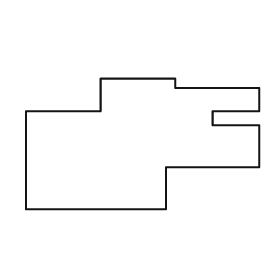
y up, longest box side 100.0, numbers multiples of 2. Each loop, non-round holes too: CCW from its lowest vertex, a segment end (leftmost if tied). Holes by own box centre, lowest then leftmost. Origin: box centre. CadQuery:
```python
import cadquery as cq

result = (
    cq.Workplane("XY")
    .moveTo(-50.0, -28.0)
    .lineTo(10.0, -28.0)
    .lineTo(10.0, -10.0)
    .lineTo(50.0, -10.0)
    .lineTo(50.0, 8.0)
    .lineTo(30.0, 8.0)
    .lineTo(30.0, 14.0)
    .lineTo(50.0, 14.0)
    .lineTo(50.0, 24.0)
    .lineTo(14.0, 24.0)
    .lineTo(14.0, 28.0)
    .lineTo(-18.0, 28.0)
    .lineTo(-18.0, 14.0)
    .lineTo(-50.0, 14.0)
    .close()
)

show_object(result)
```